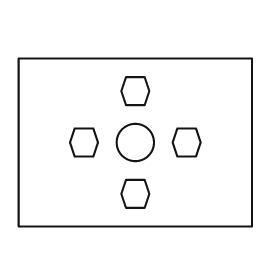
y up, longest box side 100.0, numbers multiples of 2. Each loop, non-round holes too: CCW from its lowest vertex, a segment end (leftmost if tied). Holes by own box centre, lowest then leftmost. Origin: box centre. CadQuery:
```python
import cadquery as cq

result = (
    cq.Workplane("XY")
    .moveTo(-50.0, -36.0)
    .lineTo(50.0, -36.0)
    .lineTo(50.0, 36.0)
    .lineTo(-50.0, 36.0)
    .close()
    .moveTo(-4.0, -28.0)
    .lineTo(4.0, -28.0)
    .lineTo(6.0, -22.0)
    .lineTo(4.0, -16.0)
    .lineTo(-4.0, -16.0)
    .lineTo(-6.0, -22.0)
    .close()
    .moveTo(-26.0, -6.0)
    .lineTo(-18.0, -6.0)
    .lineTo(-16.0, 0.0)
    .lineTo(-18.0, 6.0)
    .lineTo(-26.0, 6.0)
    .lineTo(-28.0, 0.0)
    .close()
    .moveTo(0.0, 0.0)
    .circle(8.0)
    .moveTo(18.0, -6.0)
    .lineTo(26.0, -6.0)
    .lineTo(28.0, 0.0)
    .lineTo(26.0, 6.0)
    .lineTo(18.0, 6.0)
    .lineTo(16.0, 0.0)
    .close()
    .moveTo(-4.0, 16.0)
    .lineTo(4.0, 16.0)
    .lineTo(6.0, 22.0)
    .lineTo(4.0, 28.0)
    .lineTo(-4.0, 28.0)
    .lineTo(-6.0, 22.0)
    .close()
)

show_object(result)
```